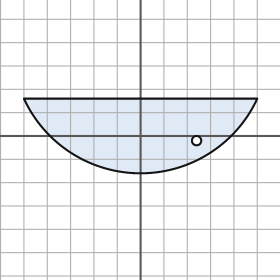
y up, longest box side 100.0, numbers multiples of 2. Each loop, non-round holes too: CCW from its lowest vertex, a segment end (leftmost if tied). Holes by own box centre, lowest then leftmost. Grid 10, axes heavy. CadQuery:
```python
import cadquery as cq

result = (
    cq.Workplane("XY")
    .moveTo(-50.0, 16.0)
    .threePointArc((0.0, -16.0), (50.0, 16.0))
    .close()
    .moveTo(24.0, -2.0)
    .circle(2.0)
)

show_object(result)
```